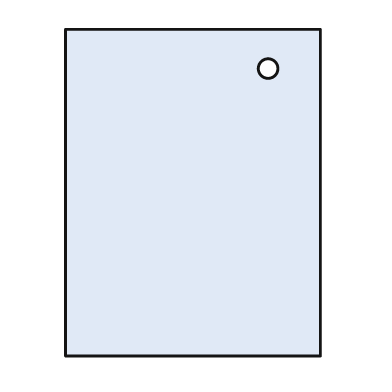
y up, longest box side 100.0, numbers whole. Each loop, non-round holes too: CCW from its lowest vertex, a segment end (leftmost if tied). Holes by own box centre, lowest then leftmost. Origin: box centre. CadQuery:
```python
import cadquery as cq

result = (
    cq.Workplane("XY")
    .moveTo(-39.0, -50.0)
    .lineTo(39.0, -50.0)
    .lineTo(39.0, 50.0)
    .lineTo(-39.0, 50.0)
    .close()
    .moveTo(23.0, 38.0)
    .circle(3.0)
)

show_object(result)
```